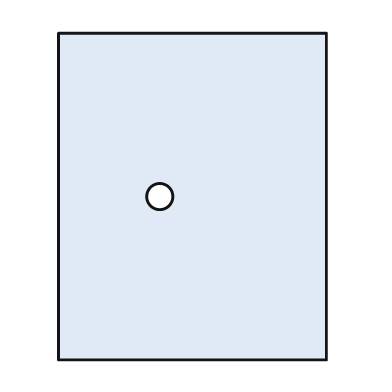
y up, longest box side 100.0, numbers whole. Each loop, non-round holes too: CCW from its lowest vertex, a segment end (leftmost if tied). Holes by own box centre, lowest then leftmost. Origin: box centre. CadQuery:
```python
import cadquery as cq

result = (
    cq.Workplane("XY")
    .moveTo(-41.0, -50.0)
    .lineTo(41.0, -50.0)
    .lineTo(41.0, 50.0)
    .lineTo(-41.0, 50.0)
    .close()
    .moveTo(-10.0, 0.0)
    .circle(4.0)
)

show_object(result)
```